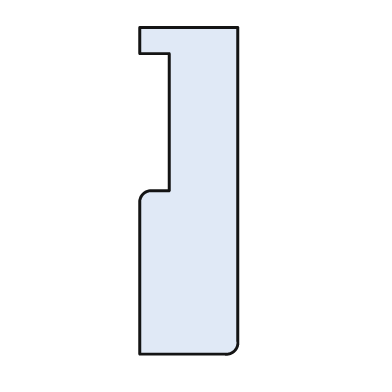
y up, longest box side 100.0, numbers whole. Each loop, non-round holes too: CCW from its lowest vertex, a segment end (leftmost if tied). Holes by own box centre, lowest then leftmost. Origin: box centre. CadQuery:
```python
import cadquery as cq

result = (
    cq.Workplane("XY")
    .moveTo(-15.0, -50.0)
    .lineTo(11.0, -50.0)
    .threePointArc((14.0, -49.0), (15.0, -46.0))
    .lineTo(15.0, 50.0)
    .lineTo(-15.0, 50.0)
    .lineTo(-15.0, 42.0)
    .lineTo(-6.0, 42.0)
    .lineTo(-6.0, 0.0)
    .lineTo(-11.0, 0.0)
    .threePointArc((-14.0, -1.0), (-15.0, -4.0))
    .close()
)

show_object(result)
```